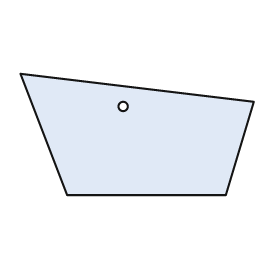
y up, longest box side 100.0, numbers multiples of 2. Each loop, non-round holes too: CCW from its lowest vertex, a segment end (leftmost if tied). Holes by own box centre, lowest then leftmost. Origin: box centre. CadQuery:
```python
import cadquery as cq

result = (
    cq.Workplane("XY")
    .moveTo(-30.0, -26.0)
    .lineTo(38.0, -26.0)
    .lineTo(50.0, 14.0)
    .lineTo(-50.0, 26.0)
    .close()
    .moveTo(-6.0, 12.0)
    .circle(2.0)
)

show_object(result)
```